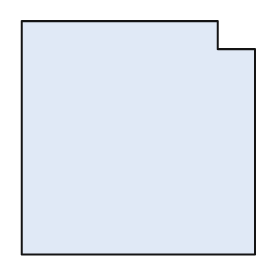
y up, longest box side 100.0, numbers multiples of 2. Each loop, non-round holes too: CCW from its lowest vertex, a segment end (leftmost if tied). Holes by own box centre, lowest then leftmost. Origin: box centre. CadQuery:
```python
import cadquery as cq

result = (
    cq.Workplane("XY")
    .moveTo(-50.0, -50.0)
    .lineTo(50.0, -50.0)
    .lineTo(50.0, 38.0)
    .lineTo(34.0, 38.0)
    .lineTo(34.0, 50.0)
    .lineTo(-50.0, 50.0)
    .close()
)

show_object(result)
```